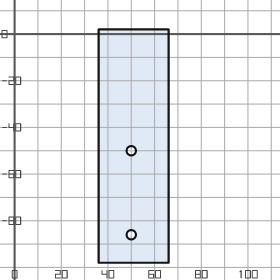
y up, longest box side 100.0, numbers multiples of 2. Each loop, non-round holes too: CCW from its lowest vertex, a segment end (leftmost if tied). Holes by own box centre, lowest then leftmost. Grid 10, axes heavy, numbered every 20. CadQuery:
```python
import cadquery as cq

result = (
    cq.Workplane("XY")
    .moveTo(36.0, -98.0)
    .lineTo(66.0, -98.0)
    .lineTo(66.0, 2.0)
    .lineTo(36.0, 2.0)
    .close()
    .moveTo(50.0, -86.0)
    .circle(2.0)
    .moveTo(50.0, -50.0)
    .circle(2.0)
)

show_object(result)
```